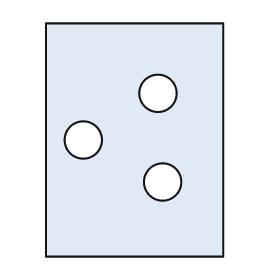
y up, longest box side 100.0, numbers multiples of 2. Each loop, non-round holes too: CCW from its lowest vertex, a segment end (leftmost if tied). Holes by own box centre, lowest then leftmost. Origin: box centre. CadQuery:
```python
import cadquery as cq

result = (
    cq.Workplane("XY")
    .moveTo(-38.0, -50.0)
    .lineTo(38.0, -50.0)
    .lineTo(38.0, 50.0)
    .lineTo(-38.0, 50.0)
    .close()
    .moveTo(12.0, -18.0)
    .circle(8.0)
    .moveTo(-22.0, 0.0)
    .circle(8.0)
    .moveTo(10.0, 20.0)
    .circle(8.0)
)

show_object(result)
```